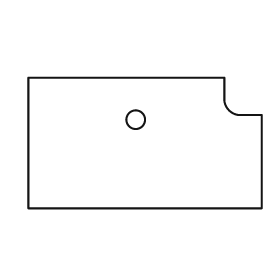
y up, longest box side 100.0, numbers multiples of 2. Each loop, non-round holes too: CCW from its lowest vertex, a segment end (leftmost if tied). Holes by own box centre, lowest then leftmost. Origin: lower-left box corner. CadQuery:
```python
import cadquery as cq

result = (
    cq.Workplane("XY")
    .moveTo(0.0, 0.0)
    .lineTo(100.0, 0.0)
    .lineTo(100.0, 40.0)
    .lineTo(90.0, 40.0)
    .threePointArc((86.0, 42.0), (84.0, 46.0))
    .lineTo(84.0, 56.0)
    .lineTo(0.0, 56.0)
    .close()
    .moveTo(46.0, 38.0)
    .circle(4.0)
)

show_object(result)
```